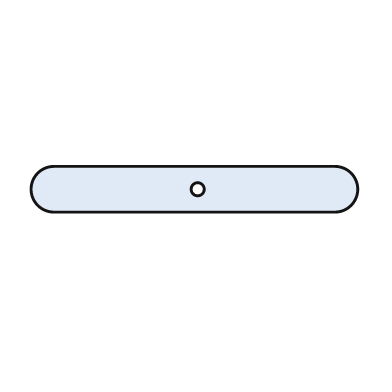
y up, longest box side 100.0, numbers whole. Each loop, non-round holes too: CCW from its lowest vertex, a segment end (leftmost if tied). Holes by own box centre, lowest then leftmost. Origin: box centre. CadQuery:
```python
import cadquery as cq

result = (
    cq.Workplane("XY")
    .moveTo(-43.0, -7.0)
    .lineTo(43.0, -7.0)
    .threePointArc((50.0, 0.0), (43.0, 7.0))
    .lineTo(-43.0, 7.0)
    .threePointArc((-50.0, 0.0), (-43.0, -7.0))
    .close()
    .moveTo(1.0, 0.0)
    .circle(2.0)
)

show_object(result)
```